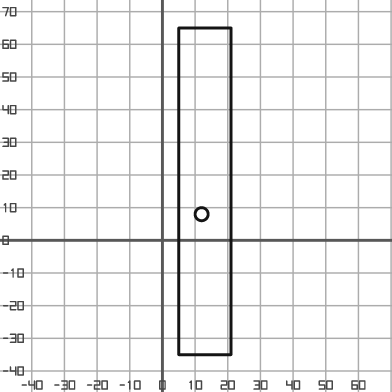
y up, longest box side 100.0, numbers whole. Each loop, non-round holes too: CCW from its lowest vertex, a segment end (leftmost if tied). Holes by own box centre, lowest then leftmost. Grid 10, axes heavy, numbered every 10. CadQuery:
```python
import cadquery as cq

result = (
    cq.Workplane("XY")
    .moveTo(5.0, -35.0)
    .lineTo(21.0, -35.0)
    .lineTo(21.0, 65.0)
    .lineTo(5.0, 65.0)
    .close()
    .moveTo(12.0, 8.0)
    .circle(2.0)
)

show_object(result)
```